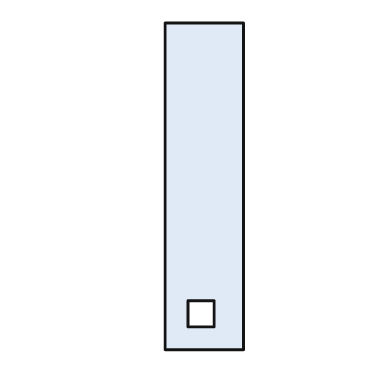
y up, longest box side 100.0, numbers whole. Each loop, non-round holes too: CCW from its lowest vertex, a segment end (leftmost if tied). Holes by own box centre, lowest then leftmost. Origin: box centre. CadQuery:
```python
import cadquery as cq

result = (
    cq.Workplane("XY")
    .moveTo(-12.0, -50.0)
    .lineTo(12.0, -50.0)
    .lineTo(12.0, 50.0)
    .lineTo(-12.0, 50.0)
    .close()
    .moveTo(-5.0, -43.0)
    .lineTo(3.0, -43.0)
    .lineTo(3.0, -35.0)
    .lineTo(-5.0, -35.0)
    .close()
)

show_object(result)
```